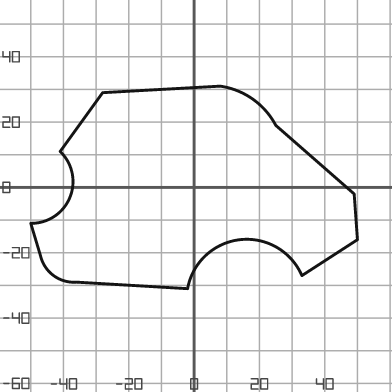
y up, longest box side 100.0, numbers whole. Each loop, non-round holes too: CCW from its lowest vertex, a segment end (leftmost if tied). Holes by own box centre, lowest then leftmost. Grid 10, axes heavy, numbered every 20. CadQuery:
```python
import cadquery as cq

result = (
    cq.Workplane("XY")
    .moveTo(-2.0, -31.0)
    .threePointArc((14.0, -16.0), (33.0, -27.0))
    .lineTo(50.0, -16.0)
    .lineTo(49.0, -2.0)
    .lineTo(25.0, 19.0)
    .threePointArc((18.0, 27.0), (8.0, 31.0))
    .lineTo(-28.0, 29.0)
    .lineTo(-41.0, 11.0)
    .threePointArc((-38.0, -3.0), (-50.0, -11.0))
    .lineTo(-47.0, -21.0)
    .threePointArc((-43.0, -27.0), (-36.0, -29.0))
    .close()
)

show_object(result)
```